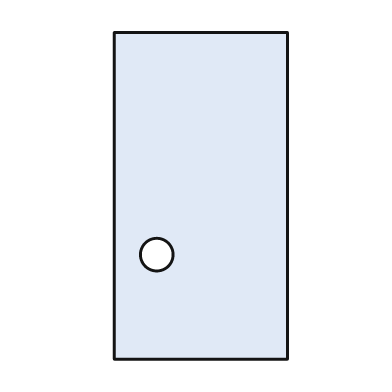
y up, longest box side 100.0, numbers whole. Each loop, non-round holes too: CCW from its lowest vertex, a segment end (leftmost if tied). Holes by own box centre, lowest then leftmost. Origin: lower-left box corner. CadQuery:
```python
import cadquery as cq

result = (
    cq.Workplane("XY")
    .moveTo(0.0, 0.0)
    .lineTo(53.0, 0.0)
    .lineTo(53.0, 100.0)
    .lineTo(0.0, 100.0)
    .close()
    .moveTo(13.0, 32.0)
    .circle(5.0)
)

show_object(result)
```